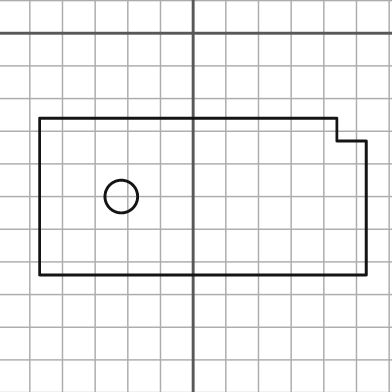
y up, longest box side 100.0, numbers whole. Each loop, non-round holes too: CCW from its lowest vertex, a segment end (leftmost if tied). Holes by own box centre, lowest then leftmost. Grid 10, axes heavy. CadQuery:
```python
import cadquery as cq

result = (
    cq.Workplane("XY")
    .moveTo(-47.0, -74.0)
    .lineTo(53.0, -74.0)
    .lineTo(53.0, -33.0)
    .lineTo(44.0, -33.0)
    .lineTo(44.0, -26.0)
    .lineTo(-47.0, -26.0)
    .close()
    .moveTo(-22.0, -50.0)
    .circle(5.0)
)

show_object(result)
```